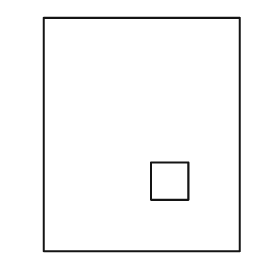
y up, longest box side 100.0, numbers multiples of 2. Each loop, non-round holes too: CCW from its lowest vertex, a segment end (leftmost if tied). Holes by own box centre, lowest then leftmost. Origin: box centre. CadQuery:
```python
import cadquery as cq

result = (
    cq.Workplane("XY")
    .moveTo(-42.0, -50.0)
    .lineTo(42.0, -50.0)
    .lineTo(42.0, 50.0)
    .lineTo(-42.0, 50.0)
    .close()
    .moveTo(4.0, -28.0)
    .lineTo(20.0, -28.0)
    .lineTo(20.0, -12.0)
    .lineTo(4.0, -12.0)
    .close()
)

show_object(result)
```